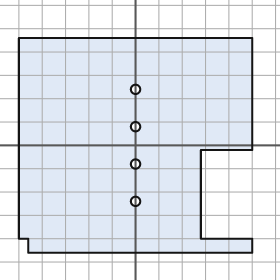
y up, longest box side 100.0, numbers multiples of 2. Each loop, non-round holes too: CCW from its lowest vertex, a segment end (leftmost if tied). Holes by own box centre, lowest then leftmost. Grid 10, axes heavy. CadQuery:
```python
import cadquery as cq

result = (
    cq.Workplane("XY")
    .moveTo(-46.0, -46.0)
    .lineTo(50.0, -46.0)
    .lineTo(50.0, -40.0)
    .lineTo(28.0, -40.0)
    .lineTo(28.0, -2.0)
    .lineTo(50.0, -2.0)
    .lineTo(50.0, 46.0)
    .lineTo(-50.0, 46.0)
    .lineTo(-50.0, -40.0)
    .lineTo(-46.0, -40.0)
    .close()
    .moveTo(0.0, -24.0)
    .circle(2.0)
    .moveTo(0.0, -8.0)
    .circle(2.0)
    .moveTo(0.0, 8.0)
    .circle(2.0)
    .moveTo(0.0, 24.0)
    .circle(2.0)
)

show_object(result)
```